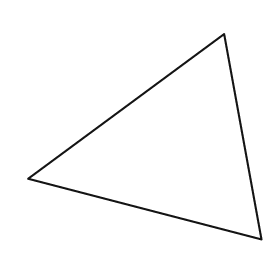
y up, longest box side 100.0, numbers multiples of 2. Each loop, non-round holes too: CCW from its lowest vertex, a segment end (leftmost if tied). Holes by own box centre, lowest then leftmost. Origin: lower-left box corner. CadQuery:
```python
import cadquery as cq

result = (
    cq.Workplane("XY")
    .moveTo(100.0, 0.0)
    .lineTo(84.0, 88.0)
    .lineTo(0.0, 26.0)
    .close()
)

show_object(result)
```